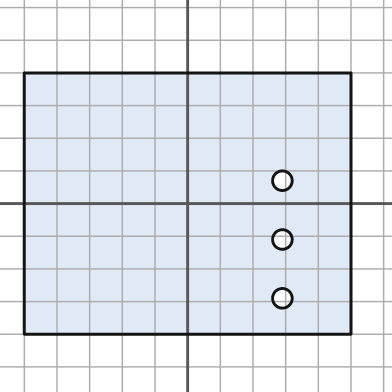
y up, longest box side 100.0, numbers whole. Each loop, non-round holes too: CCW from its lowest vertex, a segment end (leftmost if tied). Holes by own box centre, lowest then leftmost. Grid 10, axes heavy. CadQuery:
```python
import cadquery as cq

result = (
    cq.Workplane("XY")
    .moveTo(-50.0, -40.0)
    .lineTo(50.0, -40.0)
    .lineTo(50.0, 40.0)
    .lineTo(-50.0, 40.0)
    .close()
    .moveTo(29.0, -29.0)
    .circle(3.0)
    .moveTo(29.0, -11.0)
    .circle(3.0)
    .moveTo(29.0, 7.0)
    .circle(3.0)
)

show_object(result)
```